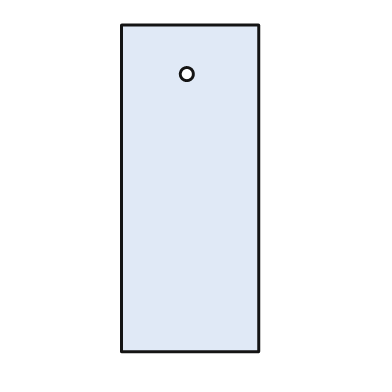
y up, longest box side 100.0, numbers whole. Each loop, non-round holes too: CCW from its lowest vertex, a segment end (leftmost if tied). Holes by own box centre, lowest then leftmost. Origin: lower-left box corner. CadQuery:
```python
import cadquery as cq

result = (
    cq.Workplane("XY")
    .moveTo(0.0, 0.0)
    .lineTo(42.0, 0.0)
    .lineTo(42.0, 100.0)
    .lineTo(0.0, 100.0)
    .close()
    .moveTo(20.0, 85.0)
    .circle(2.0)
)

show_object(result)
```